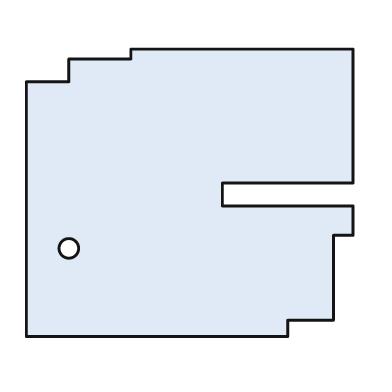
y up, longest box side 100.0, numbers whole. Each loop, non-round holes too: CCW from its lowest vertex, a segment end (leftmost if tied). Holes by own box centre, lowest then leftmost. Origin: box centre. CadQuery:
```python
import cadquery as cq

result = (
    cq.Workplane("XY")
    .moveTo(-50.0, -44.0)
    .lineTo(30.0, -44.0)
    .lineTo(30.0, -39.0)
    .lineTo(44.0, -39.0)
    .lineTo(44.0, -13.0)
    .lineTo(50.0, -13.0)
    .lineTo(50.0, -4.0)
    .lineTo(10.0, -4.0)
    .lineTo(10.0, 3.0)
    .lineTo(50.0, 3.0)
    .lineTo(50.0, 44.0)
    .lineTo(-18.0, 44.0)
    .lineTo(-18.0, 41.0)
    .lineTo(-37.0, 41.0)
    .lineTo(-37.0, 34.0)
    .lineTo(-50.0, 34.0)
    .close()
    .moveTo(-37.0, -17.0)
    .circle(3.0)
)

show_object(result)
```